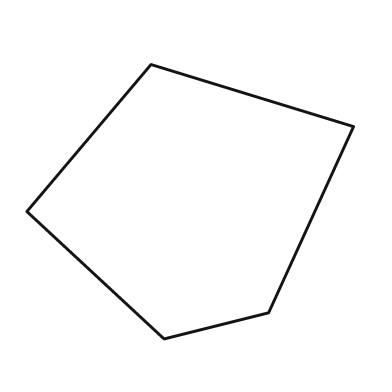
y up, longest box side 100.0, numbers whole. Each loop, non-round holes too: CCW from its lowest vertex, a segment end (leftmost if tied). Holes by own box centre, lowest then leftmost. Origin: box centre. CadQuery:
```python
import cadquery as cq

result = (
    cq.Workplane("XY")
    .moveTo(-8.0, -42.0)
    .lineTo(24.0, -34.0)
    .lineTo(50.0, 23.0)
    .lineTo(-12.0, 42.0)
    .lineTo(-50.0, -3.0)
    .close()
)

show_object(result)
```